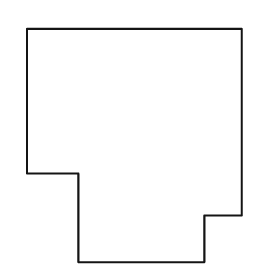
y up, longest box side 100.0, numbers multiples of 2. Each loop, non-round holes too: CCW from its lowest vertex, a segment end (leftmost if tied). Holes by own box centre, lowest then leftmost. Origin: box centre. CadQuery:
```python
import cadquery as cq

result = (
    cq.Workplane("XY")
    .moveTo(-24.0, -50.0)
    .lineTo(30.0, -50.0)
    .lineTo(30.0, -30.0)
    .lineTo(46.0, -30.0)
    .lineTo(46.0, 50.0)
    .lineTo(-46.0, 50.0)
    .lineTo(-46.0, -12.0)
    .lineTo(-24.0, -12.0)
    .close()
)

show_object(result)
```